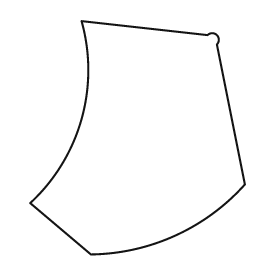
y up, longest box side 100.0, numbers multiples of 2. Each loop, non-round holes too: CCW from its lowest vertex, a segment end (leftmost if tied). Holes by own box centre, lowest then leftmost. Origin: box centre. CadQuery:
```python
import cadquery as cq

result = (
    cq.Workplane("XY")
    .moveTo(-20.0, -50.0)
    .threePointArc((16.0, -42.0), (46.0, -20.0))
    .lineTo(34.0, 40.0)
    .threePointArc((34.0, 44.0), (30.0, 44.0))
    .lineTo(-24.0, 50.0)
    .threePointArc((-24.0, 8.0), (-46.0, -28.0))
    .close()
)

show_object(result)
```